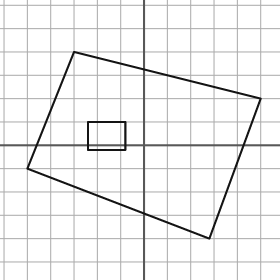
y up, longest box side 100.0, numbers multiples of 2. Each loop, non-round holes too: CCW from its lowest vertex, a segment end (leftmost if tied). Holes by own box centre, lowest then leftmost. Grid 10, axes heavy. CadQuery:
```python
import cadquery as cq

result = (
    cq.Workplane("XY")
    .moveTo(28.0, -40.0)
    .lineTo(50.0, 20.0)
    .lineTo(-30.0, 40.0)
    .lineTo(-50.0, -10.0)
    .close()
    .moveTo(-24.0, -2.0)
    .lineTo(-8.0, -2.0)
    .lineTo(-8.0, 10.0)
    .lineTo(-24.0, 10.0)
    .close()
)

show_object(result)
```